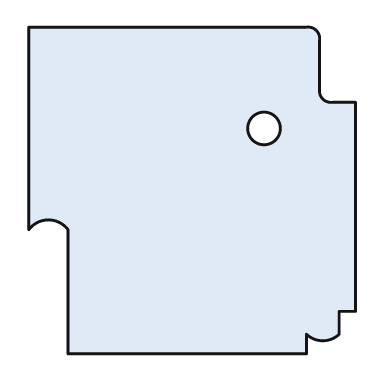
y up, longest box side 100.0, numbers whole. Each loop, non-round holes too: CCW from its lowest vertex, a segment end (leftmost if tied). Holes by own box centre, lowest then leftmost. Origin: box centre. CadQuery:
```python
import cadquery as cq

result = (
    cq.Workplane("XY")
    .moveTo(-38.0, -50.0)
    .lineTo(35.0, -50.0)
    .lineTo(35.0, -44.0)
    .threePointArc((40.0, -46.0), (45.0, -44.0))
    .lineTo(45.0, -37.0)
    .lineTo(50.0, -37.0)
    .lineTo(50.0, 27.0)
    .lineTo(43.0, 27.0)
    .threePointArc((40.0, 28.0), (39.0, 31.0))
    .lineTo(39.0, 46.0)
    .threePointArc((38.0, 49.0), (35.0, 50.0))
    .lineTo(-50.0, 50.0)
    .lineTo(-50.0, -12.0)
    .threePointArc((-44.0, -9.0), (-38.0, -12.0))
    .close()
    .moveTo(22.0, 19.0)
    .circle(5.0)
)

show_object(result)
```